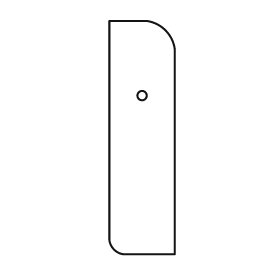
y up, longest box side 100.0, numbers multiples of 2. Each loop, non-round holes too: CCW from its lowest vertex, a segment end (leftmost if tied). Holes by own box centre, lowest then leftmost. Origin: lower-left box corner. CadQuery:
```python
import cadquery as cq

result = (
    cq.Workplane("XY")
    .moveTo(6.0, 0.0)
    .lineTo(28.0, 0.0)
    .lineTo(28.0, 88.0)
    .threePointArc((24.0, 96.0), (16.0, 100.0))
    .lineTo(0.0, 100.0)
    .lineTo(0.0, 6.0)
    .threePointArc((2.0, 2.0), (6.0, 0.0))
    .close()
    .moveTo(14.0, 68.0)
    .circle(2.0)
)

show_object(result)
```